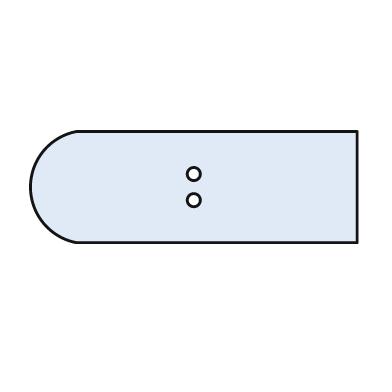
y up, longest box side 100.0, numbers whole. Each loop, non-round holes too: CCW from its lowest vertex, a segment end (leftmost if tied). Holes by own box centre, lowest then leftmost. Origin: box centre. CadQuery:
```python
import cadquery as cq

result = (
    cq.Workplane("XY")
    .moveTo(-36.0, -17.0)
    .lineTo(50.0, -17.0)
    .lineTo(50.0, 17.0)
    .lineTo(-36.0, 17.0)
    .threePointArc((-50.0, 0.0), (-36.0, -17.0))
    .close()
    .moveTo(0.0, -4.0)
    .circle(2.0)
    .moveTo(0.0, 4.0)
    .circle(2.0)
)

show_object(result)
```